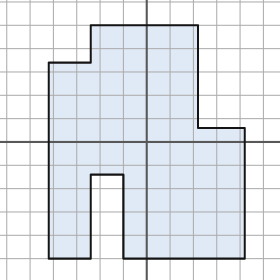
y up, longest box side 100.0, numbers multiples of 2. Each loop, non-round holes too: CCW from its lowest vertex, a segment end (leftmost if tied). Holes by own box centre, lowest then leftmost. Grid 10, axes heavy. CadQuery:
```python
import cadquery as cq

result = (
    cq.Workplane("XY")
    .moveTo(-42.0, -50.0)
    .lineTo(-24.0, -50.0)
    .lineTo(-24.0, -14.0)
    .lineTo(-10.0, -14.0)
    .lineTo(-10.0, -50.0)
    .lineTo(42.0, -50.0)
    .lineTo(42.0, 6.0)
    .lineTo(22.0, 6.0)
    .lineTo(22.0, 50.0)
    .lineTo(-24.0, 50.0)
    .lineTo(-24.0, 34.0)
    .lineTo(-42.0, 34.0)
    .close()
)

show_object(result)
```